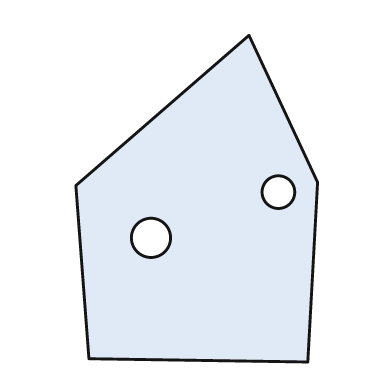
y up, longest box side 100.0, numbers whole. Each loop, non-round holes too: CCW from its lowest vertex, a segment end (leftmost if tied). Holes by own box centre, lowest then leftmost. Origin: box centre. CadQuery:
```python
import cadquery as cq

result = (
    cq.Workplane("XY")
    .moveTo(34.0, -50.0)
    .lineTo(37.0, 5.0)
    .lineTo(16.0, 50.0)
    .lineTo(-37.0, 4.0)
    .lineTo(-33.0, -49.0)
    .close()
    .moveTo(-14.0, -12.0)
    .circle(6.0)
    .moveTo(25.0, 2.0)
    .circle(5.0)
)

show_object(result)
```